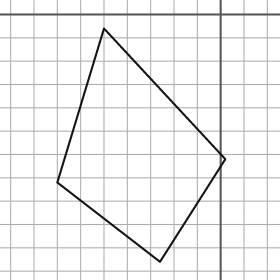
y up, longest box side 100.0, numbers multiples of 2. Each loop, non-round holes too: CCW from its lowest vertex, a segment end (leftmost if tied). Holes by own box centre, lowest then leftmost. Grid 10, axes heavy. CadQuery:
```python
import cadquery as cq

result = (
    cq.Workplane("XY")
    .moveTo(-26.0, -106.0)
    .lineTo(2.0, -62.0)
    .lineTo(-50.0, -6.0)
    .lineTo(-70.0, -72.0)
    .close()
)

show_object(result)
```